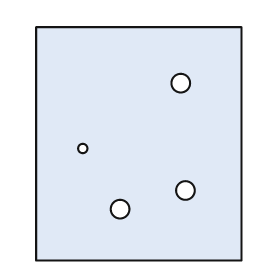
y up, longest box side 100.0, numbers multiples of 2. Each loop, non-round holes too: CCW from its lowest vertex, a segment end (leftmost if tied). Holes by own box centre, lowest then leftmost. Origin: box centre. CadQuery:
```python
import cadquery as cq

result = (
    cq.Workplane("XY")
    .moveTo(-44.0, -50.0)
    .lineTo(44.0, -50.0)
    .lineTo(44.0, 50.0)
    .lineTo(-44.0, 50.0)
    .close()
    .moveTo(-8.0, -28.0)
    .circle(4.0)
    .moveTo(20.0, -20.0)
    .circle(4.0)
    .moveTo(-24.0, -2.0)
    .circle(2.0)
    .moveTo(18.0, 26.0)
    .circle(4.0)
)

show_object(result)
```